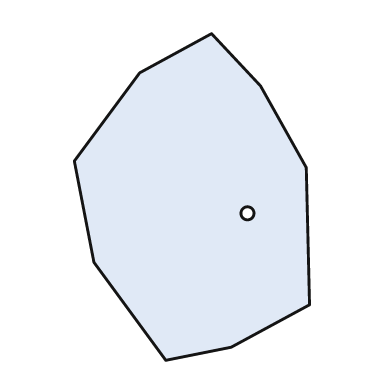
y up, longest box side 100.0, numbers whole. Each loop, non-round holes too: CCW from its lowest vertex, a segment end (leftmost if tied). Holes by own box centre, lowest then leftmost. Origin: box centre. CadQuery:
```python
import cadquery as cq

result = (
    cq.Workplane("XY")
    .moveTo(-8.0, -50.0)
    .lineTo(12.0, -46.0)
    .lineTo(36.0, -33.0)
    .lineTo(35.0, 9.0)
    .lineTo(21.0, 34.0)
    .lineTo(6.0, 50.0)
    .lineTo(-16.0, 38.0)
    .lineTo(-36.0, 11.0)
    .lineTo(-30.0, -20.0)
    .close()
    .moveTo(17.0, -5.0)
    .circle(2.0)
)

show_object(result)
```